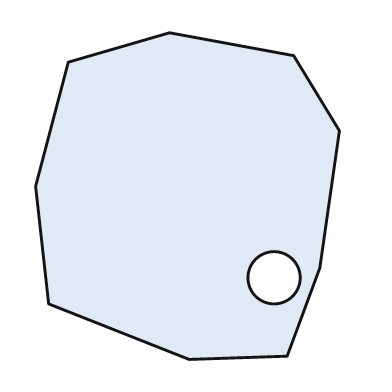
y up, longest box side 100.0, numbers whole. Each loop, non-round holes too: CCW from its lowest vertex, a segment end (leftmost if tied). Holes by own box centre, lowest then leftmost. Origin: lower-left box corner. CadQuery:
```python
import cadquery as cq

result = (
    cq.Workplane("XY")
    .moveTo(47.0, 0.0)
    .lineTo(77.0, 1.0)
    .lineTo(87.0, 28.0)
    .lineTo(93.0, 70.0)
    .lineTo(79.0, 93.0)
    .lineTo(41.0, 100.0)
    .lineTo(10.0, 91.0)
    .lineTo(0.0, 53.0)
    .lineTo(4.0, 17.0)
    .close()
    .moveTo(73.0, 25.0)
    .circle(8.0)
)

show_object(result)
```